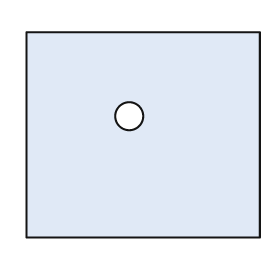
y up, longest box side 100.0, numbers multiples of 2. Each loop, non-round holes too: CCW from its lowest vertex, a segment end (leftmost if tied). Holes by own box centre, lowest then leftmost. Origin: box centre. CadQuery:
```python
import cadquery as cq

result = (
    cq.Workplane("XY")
    .moveTo(-50.0, -44.0)
    .lineTo(50.0, -44.0)
    .lineTo(50.0, 44.0)
    .lineTo(-50.0, 44.0)
    .close()
    .moveTo(-6.0, 8.0)
    .circle(6.0)
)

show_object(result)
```